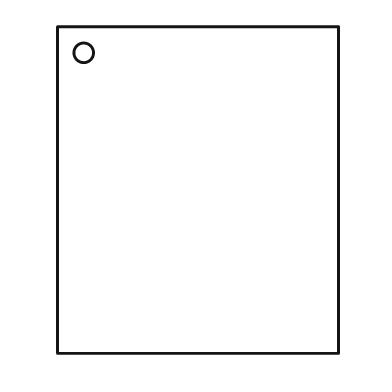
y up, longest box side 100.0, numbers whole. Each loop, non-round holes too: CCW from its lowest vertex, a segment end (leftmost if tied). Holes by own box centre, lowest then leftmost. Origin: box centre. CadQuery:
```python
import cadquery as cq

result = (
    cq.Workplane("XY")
    .moveTo(-43.0, -50.0)
    .lineTo(43.0, -50.0)
    .lineTo(43.0, 50.0)
    .lineTo(-43.0, 50.0)
    .close()
    .moveTo(-35.0, 42.0)
    .circle(3.0)
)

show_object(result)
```